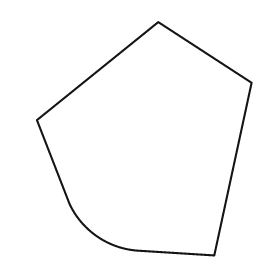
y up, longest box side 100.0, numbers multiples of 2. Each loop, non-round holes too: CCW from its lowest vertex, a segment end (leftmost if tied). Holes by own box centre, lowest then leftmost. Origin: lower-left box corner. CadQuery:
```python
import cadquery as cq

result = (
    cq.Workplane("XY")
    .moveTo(76.0, 0.0)
    .lineTo(92.0, 74.0)
    .lineTo(52.0, 100.0)
    .lineTo(0.0, 58.0)
    .lineTo(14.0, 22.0)
    .threePointArc((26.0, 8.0), (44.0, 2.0))
    .close()
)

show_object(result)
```